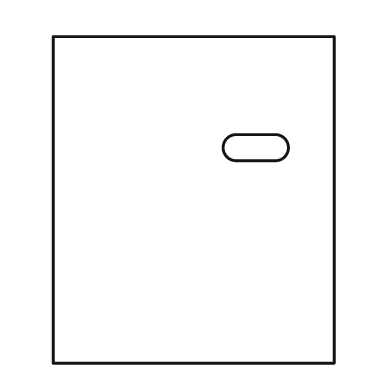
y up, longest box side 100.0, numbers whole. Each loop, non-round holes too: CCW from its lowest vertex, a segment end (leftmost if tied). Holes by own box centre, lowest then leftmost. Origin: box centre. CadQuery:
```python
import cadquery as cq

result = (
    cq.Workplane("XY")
    .moveTo(-43.0, -50.0)
    .lineTo(43.0, -50.0)
    .lineTo(43.0, 50.0)
    .lineTo(-43.0, 50.0)
    .close()
    .moveTo(13.0, 12.0)
    .lineTo(25.0, 12.0)
    .threePointArc((29.0, 16.0), (25.0, 20.0))
    .lineTo(13.0, 20.0)
    .threePointArc((9.0, 16.0), (13.0, 12.0))
    .close()
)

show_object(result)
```